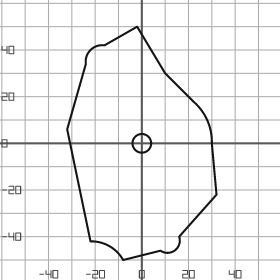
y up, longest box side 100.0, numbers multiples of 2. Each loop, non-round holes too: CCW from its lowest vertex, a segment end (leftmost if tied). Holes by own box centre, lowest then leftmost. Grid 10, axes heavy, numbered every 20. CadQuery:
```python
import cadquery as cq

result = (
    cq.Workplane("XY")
    .moveTo(-8.0, -50.0)
    .lineTo(8.0, -46.0)
    .threePointArc((14.0, -46.0), (16.0, -40.0))
    .lineTo(32.0, -22.0)
    .lineTo(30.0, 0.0)
    .threePointArc((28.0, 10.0), (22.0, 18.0))
    .lineTo(10.0, 30.0)
    .lineTo(-2.0, 50.0)
    .lineTo(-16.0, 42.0)
    .threePointArc((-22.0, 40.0), (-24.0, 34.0))
    .lineTo(-32.0, 6.0)
    .lineTo(-22.0, -42.0)
    .threePointArc((-14.0, -44.0), (-8.0, -50.0))
    .close()
    .moveTo(0.0, 0.0)
    .circle(4.0)
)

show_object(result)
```